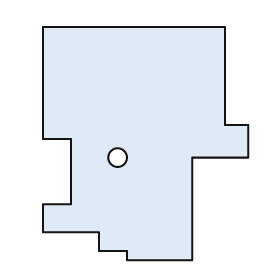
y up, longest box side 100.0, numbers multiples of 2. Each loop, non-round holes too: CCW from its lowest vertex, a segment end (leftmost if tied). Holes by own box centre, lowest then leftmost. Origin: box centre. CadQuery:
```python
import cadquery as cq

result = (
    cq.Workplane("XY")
    .moveTo(-8.0, -50.0)
    .lineTo(20.0, -50.0)
    .lineTo(20.0, -6.0)
    .lineTo(44.0, -6.0)
    .lineTo(44.0, 8.0)
    .lineTo(34.0, 8.0)
    .lineTo(34.0, 50.0)
    .lineTo(-44.0, 50.0)
    .lineTo(-44.0, 2.0)
    .lineTo(-32.0, 2.0)
    .lineTo(-32.0, -26.0)
    .lineTo(-44.0, -26.0)
    .lineTo(-44.0, -38.0)
    .lineTo(-20.0, -38.0)
    .lineTo(-20.0, -46.0)
    .lineTo(-8.0, -46.0)
    .close()
    .moveTo(-12.0, -6.0)
    .circle(4.0)
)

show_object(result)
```